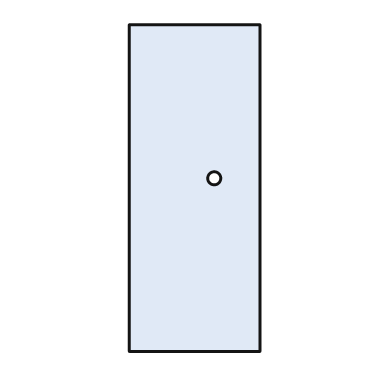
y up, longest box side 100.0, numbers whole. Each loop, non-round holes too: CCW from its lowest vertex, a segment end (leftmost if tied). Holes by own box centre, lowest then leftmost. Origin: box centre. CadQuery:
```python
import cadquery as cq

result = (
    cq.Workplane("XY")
    .moveTo(-20.0, -50.0)
    .lineTo(20.0, -50.0)
    .lineTo(20.0, 50.0)
    .lineTo(-20.0, 50.0)
    .close()
    .moveTo(6.0, 3.0)
    .circle(2.0)
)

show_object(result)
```